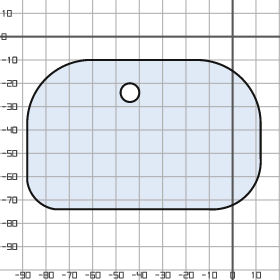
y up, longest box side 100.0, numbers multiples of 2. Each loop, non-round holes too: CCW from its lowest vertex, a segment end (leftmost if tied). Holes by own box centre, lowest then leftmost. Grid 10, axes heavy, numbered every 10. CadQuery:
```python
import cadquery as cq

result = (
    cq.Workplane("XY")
    .moveTo(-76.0, -74.0)
    .lineTo(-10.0, -74.0)
    .threePointArc((6.0, -68.0), (12.0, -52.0))
    .lineTo(12.0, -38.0)
    .threePointArc((4.0, -18.0), (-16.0, -10.0))
    .lineTo(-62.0, -10.0)
    .threePointArc((-80.0, -18.0), (-88.0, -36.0))
    .lineTo(-88.0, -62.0)
    .threePointArc((-84.0, -70.0), (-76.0, -74.0))
    .close()
    .moveTo(-44.0, -24.0)
    .circle(4.0)
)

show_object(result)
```